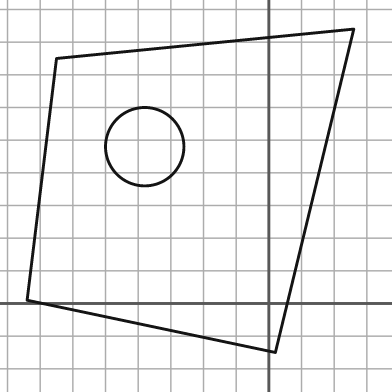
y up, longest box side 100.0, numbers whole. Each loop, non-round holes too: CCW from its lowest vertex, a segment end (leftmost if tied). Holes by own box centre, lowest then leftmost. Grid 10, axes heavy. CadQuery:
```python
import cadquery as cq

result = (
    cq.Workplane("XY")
    .moveTo(2.0, -15.0)
    .lineTo(26.0, 84.0)
    .lineTo(-65.0, 75.0)
    .lineTo(-74.0, 1.0)
    .close()
    .moveTo(-38.0, 48.0)
    .circle(12.0)
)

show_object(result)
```